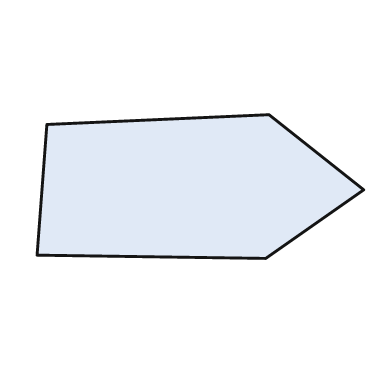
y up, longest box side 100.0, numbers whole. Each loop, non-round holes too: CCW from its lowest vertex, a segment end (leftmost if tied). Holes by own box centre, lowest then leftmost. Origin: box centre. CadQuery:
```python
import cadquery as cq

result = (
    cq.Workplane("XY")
    .moveTo(20.0, -22.0)
    .lineTo(50.0, -1.0)
    .lineTo(21.0, 22.0)
    .lineTo(-47.0, 19.0)
    .lineTo(-50.0, -21.0)
    .close()
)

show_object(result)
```